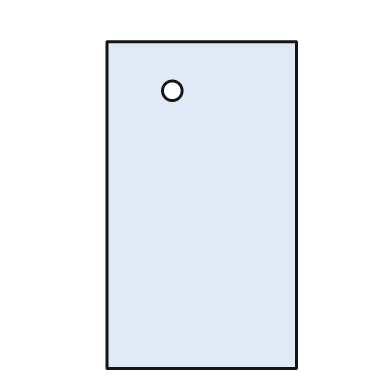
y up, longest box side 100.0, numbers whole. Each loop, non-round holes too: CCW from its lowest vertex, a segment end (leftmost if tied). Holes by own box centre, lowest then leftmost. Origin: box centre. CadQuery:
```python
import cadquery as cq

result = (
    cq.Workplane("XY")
    .moveTo(-29.0, -50.0)
    .lineTo(29.0, -50.0)
    .lineTo(29.0, 50.0)
    .lineTo(-29.0, 50.0)
    .close()
    .moveTo(-9.0, 35.0)
    .circle(3.0)
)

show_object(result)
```